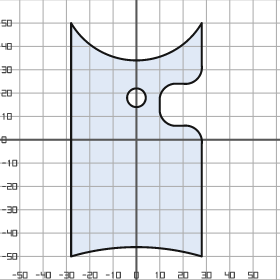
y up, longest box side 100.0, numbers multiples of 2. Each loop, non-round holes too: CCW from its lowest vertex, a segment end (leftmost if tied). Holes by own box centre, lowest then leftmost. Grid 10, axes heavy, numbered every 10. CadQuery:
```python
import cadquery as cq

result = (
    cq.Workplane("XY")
    .moveTo(-28.0, -50.0)
    .threePointArc((0.0, -46.0), (28.0, -50.0))
    .lineTo(28.0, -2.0)
    .threePointArc((26.0, 4.0), (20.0, 6.0))
    .lineTo(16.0, 6.0)
    .threePointArc((12.0, 8.0), (10.0, 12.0))
    .lineTo(10.0, 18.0)
    .threePointArc((12.0, 22.0), (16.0, 24.0))
    .lineTo(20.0, 24.0)
    .threePointArc((26.0, 26.0), (28.0, 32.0))
    .lineTo(28.0, 50.0)
    .threePointArc((0.0, 34.0), (-28.0, 50.0))
    .close()
    .moveTo(0.0, 18.0)
    .circle(4.0)
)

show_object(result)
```